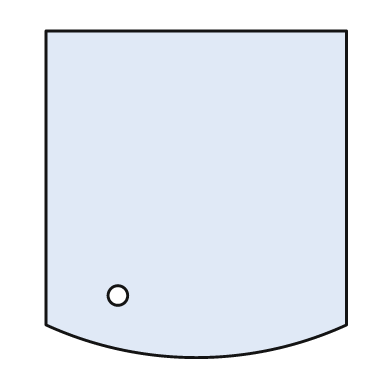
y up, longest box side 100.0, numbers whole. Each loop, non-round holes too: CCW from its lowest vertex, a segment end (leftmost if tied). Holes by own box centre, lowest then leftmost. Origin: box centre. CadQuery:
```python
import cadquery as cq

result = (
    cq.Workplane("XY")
    .moveTo(-46.0, -40.0)
    .threePointArc((0.0, -50.0), (46.0, -40.0))
    .lineTo(46.0, 50.0)
    .lineTo(-46.0, 50.0)
    .close()
    .moveTo(-24.0, -31.0)
    .circle(3.0)
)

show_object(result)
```